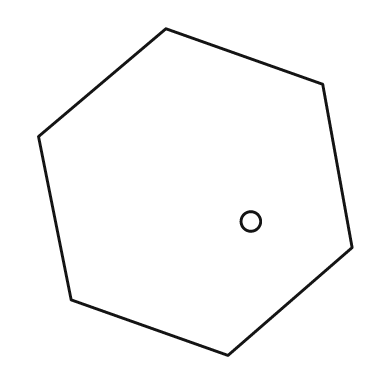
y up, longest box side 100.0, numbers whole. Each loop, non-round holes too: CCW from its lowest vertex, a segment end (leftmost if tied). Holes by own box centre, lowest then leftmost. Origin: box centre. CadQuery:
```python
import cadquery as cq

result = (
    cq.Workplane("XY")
    .moveTo(10.0, -50.0)
    .lineTo(48.0, -17.0)
    .lineTo(39.0, 33.0)
    .lineTo(-9.0, 50.0)
    .lineTo(-48.0, 17.0)
    .lineTo(-38.0, -33.0)
    .close()
    .moveTo(17.0, -9.0)
    .circle(3.0)
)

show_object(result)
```